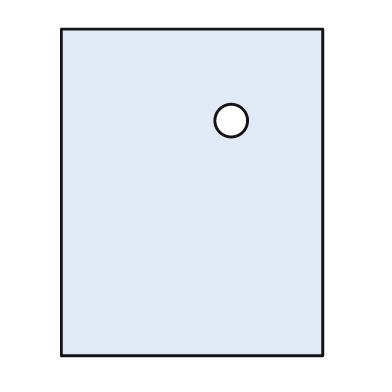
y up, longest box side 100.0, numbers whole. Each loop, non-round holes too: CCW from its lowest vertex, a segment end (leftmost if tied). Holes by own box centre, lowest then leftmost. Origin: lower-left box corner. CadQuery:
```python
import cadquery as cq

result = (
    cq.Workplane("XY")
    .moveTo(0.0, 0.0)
    .lineTo(80.0, 0.0)
    .lineTo(80.0, 100.0)
    .lineTo(0.0, 100.0)
    .close()
    .moveTo(52.0, 72.0)
    .circle(5.0)
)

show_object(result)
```